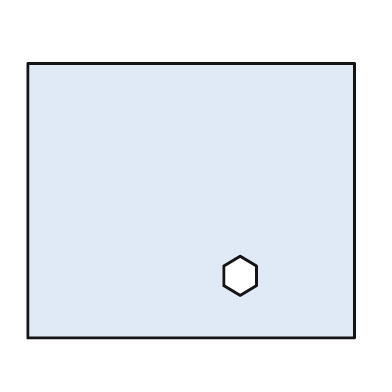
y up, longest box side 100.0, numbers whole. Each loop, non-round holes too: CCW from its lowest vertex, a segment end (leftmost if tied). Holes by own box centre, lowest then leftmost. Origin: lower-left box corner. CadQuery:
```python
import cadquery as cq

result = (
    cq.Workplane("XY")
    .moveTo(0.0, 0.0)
    .lineTo(100.0, 0.0)
    .lineTo(100.0, 84.0)
    .lineTo(0.0, 84.0)
    .close()
    .moveTo(65.0, 13.0)
    .lineTo(70.0, 16.0)
    .lineTo(70.0, 22.0)
    .lineTo(65.0, 25.0)
    .lineTo(60.0, 22.0)
    .lineTo(60.0, 16.0)
    .close()
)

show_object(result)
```